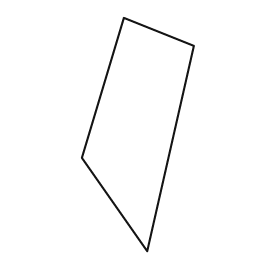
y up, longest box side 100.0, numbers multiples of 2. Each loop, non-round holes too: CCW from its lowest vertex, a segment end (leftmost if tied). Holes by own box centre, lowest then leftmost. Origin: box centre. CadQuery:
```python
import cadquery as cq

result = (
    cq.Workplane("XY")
    .moveTo(4.0, -50.0)
    .lineTo(24.0, 38.0)
    .lineTo(-6.0, 50.0)
    .lineTo(-24.0, -10.0)
    .close()
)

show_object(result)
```